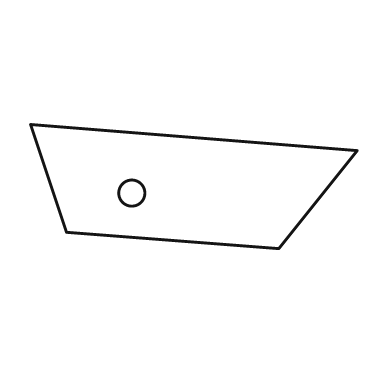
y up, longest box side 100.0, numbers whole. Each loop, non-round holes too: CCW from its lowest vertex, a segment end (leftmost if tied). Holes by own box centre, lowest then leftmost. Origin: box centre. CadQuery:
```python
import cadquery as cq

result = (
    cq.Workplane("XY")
    .moveTo(26.0, -19.0)
    .lineTo(50.0, 11.0)
    .lineTo(-50.0, 19.0)
    .lineTo(-39.0, -14.0)
    .close()
    .moveTo(-19.0, -2.0)
    .circle(4.0)
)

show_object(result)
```